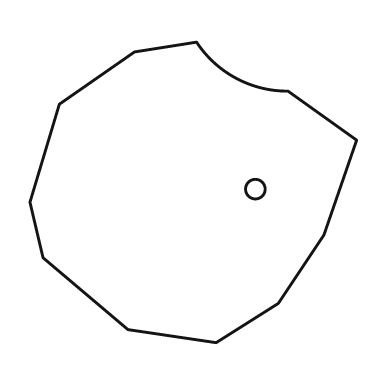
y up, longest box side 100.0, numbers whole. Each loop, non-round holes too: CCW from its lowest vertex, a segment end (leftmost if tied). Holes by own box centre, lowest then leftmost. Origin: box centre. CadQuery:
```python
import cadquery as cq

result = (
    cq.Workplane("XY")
    .moveTo(7.0, -46.0)
    .lineTo(26.0, -34.0)
    .lineTo(40.0, -13.0)
    .lineTo(50.0, 16.0)
    .lineTo(29.0, 31.0)
    .threePointArc((13.0, 35.0), (1.0, 46.0))
    .lineTo(-18.0, 43.0)
    .lineTo(-41.0, 27.0)
    .lineTo(-50.0, -3.0)
    .lineTo(-46.0, -20.0)
    .lineTo(-20.0, -42.0)
    .close()
    .moveTo(19.0, 1.0)
    .circle(3.0)
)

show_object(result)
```